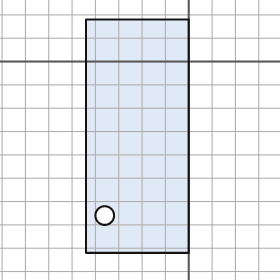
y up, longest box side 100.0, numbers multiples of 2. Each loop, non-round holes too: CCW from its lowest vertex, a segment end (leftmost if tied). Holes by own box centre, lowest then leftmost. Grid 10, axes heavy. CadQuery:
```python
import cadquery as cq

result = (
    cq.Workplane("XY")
    .moveTo(-44.0, -82.0)
    .lineTo(0.0, -82.0)
    .lineTo(0.0, 18.0)
    .lineTo(-44.0, 18.0)
    .close()
    .moveTo(-36.0, -66.0)
    .circle(4.0)
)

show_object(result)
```